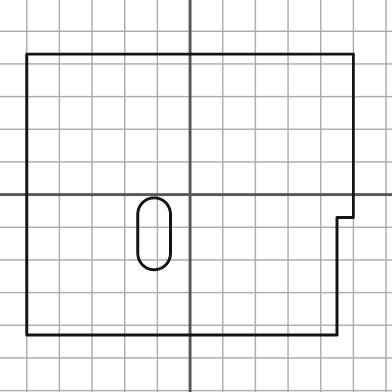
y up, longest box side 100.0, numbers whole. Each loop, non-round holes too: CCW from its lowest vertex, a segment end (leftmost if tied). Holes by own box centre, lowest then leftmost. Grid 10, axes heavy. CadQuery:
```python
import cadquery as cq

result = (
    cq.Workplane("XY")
    .moveTo(-50.0, -43.0)
    .lineTo(45.0, -43.0)
    .lineTo(45.0, -7.0)
    .lineTo(50.0, -7.0)
    .lineTo(50.0, 43.0)
    .lineTo(-50.0, 43.0)
    .close()
    .moveTo(-16.0, -18.0)
    .threePointArc((-11.0, -23.0), (-6.0, -18.0))
    .lineTo(-6.0, -6.0)
    .threePointArc((-11.0, -1.0), (-16.0, -6.0))
    .close()
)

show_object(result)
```